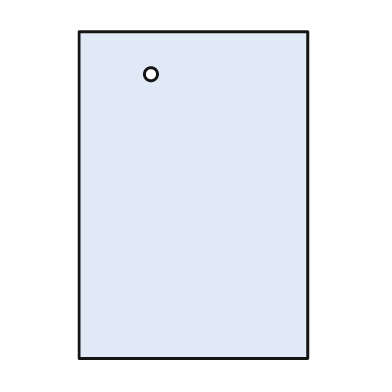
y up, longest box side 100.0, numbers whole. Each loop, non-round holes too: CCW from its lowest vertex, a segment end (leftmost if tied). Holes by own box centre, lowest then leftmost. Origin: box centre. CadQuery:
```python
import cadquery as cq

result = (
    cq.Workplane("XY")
    .moveTo(-35.0, -50.0)
    .lineTo(35.0, -50.0)
    .lineTo(35.0, 50.0)
    .lineTo(-35.0, 50.0)
    .close()
    .moveTo(-13.0, 37.0)
    .circle(2.0)
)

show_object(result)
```